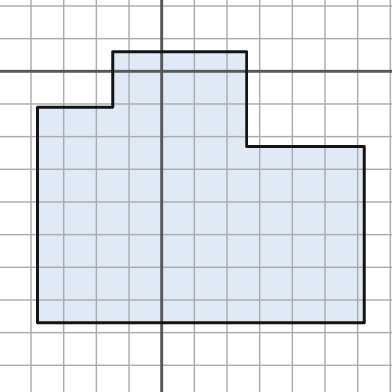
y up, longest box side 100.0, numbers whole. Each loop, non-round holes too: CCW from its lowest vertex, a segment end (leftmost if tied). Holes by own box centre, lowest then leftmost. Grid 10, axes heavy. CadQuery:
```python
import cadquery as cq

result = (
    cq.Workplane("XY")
    .moveTo(-38.0, -77.0)
    .lineTo(62.0, -77.0)
    .lineTo(62.0, -23.0)
    .lineTo(26.0, -23.0)
    .lineTo(26.0, 6.0)
    .lineTo(-15.0, 6.0)
    .lineTo(-15.0, -11.0)
    .lineTo(-38.0, -11.0)
    .close()
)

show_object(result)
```